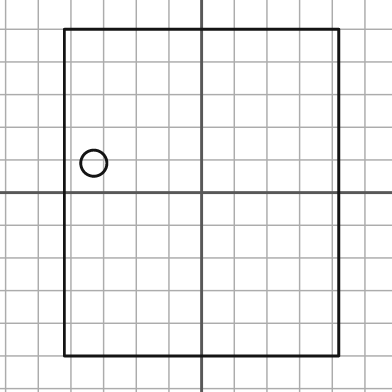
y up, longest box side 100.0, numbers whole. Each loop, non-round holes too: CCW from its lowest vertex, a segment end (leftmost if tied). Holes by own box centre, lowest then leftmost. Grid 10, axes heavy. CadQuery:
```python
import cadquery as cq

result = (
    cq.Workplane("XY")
    .moveTo(-42.0, -50.0)
    .lineTo(42.0, -50.0)
    .lineTo(42.0, 50.0)
    .lineTo(-42.0, 50.0)
    .close()
    .moveTo(-33.0, 9.0)
    .circle(4.0)
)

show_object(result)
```